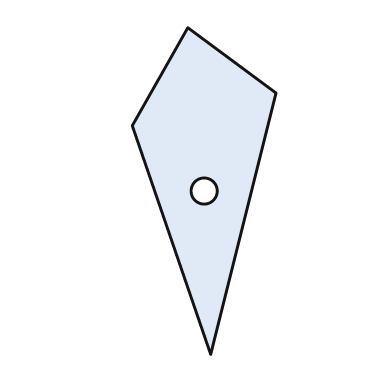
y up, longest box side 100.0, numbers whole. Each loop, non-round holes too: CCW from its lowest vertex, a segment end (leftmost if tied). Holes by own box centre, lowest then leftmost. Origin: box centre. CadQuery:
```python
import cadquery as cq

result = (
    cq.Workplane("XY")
    .moveTo(2.0, -50.0)
    .lineTo(22.0, 30.0)
    .lineTo(-5.0, 50.0)
    .lineTo(-22.0, 20.0)
    .close()
    .moveTo(0.0, 0.0)
    .circle(4.0)
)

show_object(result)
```